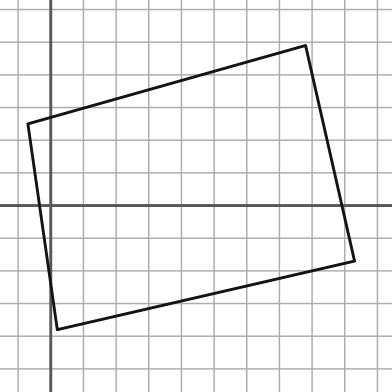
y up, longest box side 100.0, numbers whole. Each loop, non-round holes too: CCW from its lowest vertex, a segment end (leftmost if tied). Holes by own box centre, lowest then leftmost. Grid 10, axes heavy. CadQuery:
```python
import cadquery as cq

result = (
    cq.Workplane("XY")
    .moveTo(2.0, -38.0)
    .lineTo(93.0, -17.0)
    .lineTo(78.0, 49.0)
    .lineTo(-7.0, 25.0)
    .close()
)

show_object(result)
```